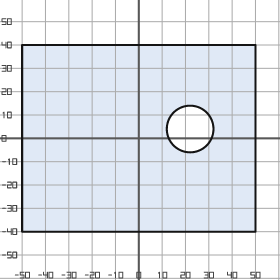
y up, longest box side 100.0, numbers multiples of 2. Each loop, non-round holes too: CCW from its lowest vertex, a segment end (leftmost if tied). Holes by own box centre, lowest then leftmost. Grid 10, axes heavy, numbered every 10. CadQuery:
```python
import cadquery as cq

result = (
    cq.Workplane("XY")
    .moveTo(-50.0, -40.0)
    .lineTo(50.0, -40.0)
    .lineTo(50.0, 40.0)
    .lineTo(-50.0, 40.0)
    .close()
    .moveTo(22.0, 4.0)
    .circle(10.0)
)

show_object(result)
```